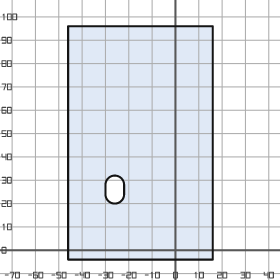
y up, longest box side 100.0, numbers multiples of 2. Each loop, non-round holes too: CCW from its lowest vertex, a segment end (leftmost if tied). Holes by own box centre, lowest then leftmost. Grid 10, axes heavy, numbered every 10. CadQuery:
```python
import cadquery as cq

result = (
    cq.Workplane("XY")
    .moveTo(-46.0, -4.0)
    .lineTo(16.0, -4.0)
    .lineTo(16.0, 96.0)
    .lineTo(-46.0, 96.0)
    .close()
    .moveTo(-30.0, 24.0)
    .threePointArc((-26.0, 20.0), (-22.0, 24.0))
    .lineTo(-22.0, 28.0)
    .threePointArc((-26.0, 32.0), (-30.0, 28.0))
    .close()
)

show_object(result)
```